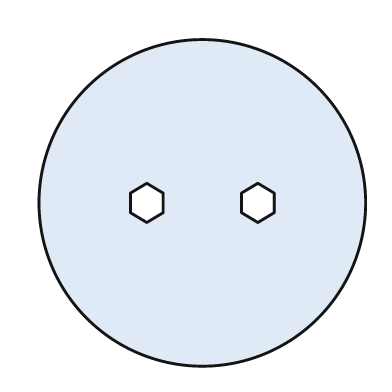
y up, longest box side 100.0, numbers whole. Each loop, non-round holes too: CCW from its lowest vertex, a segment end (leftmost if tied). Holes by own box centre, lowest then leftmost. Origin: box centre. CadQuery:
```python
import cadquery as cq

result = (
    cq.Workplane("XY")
    .moveTo(0.0, 0.0)
    .circle(50.0)
    .moveTo(-17.0, -6.0)
    .lineTo(-12.0, -3.0)
    .lineTo(-12.0, 3.0)
    .lineTo(-17.0, 6.0)
    .lineTo(-22.0, 3.0)
    .lineTo(-22.0, -3.0)
    .close()
    .moveTo(17.0, -6.0)
    .lineTo(22.0, -3.0)
    .lineTo(22.0, 3.0)
    .lineTo(17.0, 6.0)
    .lineTo(12.0, 3.0)
    .lineTo(12.0, -3.0)
    .close()
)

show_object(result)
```